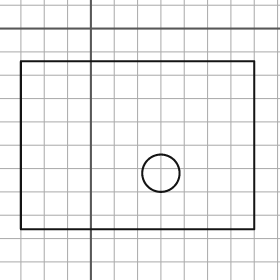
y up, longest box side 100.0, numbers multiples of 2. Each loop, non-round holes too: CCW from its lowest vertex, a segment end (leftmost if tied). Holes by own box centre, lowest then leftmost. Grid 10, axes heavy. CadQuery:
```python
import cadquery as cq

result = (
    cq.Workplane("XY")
    .moveTo(-30.0, -86.0)
    .lineTo(70.0, -86.0)
    .lineTo(70.0, -14.0)
    .lineTo(-30.0, -14.0)
    .close()
    .moveTo(30.0, -62.0)
    .circle(8.0)
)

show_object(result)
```